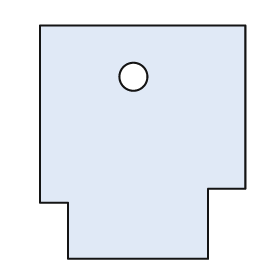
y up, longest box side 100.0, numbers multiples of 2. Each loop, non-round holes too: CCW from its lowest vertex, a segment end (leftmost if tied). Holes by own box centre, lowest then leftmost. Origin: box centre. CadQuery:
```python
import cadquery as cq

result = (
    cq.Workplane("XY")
    .moveTo(-32.0, -50.0)
    .lineTo(28.0, -50.0)
    .lineTo(28.0, -20.0)
    .lineTo(44.0, -20.0)
    .lineTo(44.0, 50.0)
    .lineTo(-44.0, 50.0)
    .lineTo(-44.0, -26.0)
    .lineTo(-32.0, -26.0)
    .close()
    .moveTo(-4.0, 28.0)
    .circle(6.0)
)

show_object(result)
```